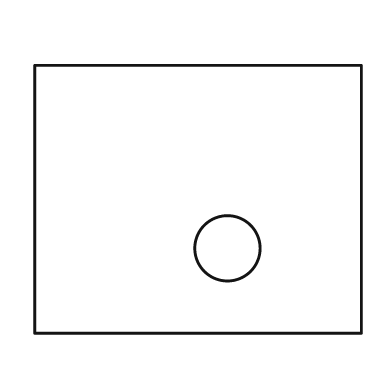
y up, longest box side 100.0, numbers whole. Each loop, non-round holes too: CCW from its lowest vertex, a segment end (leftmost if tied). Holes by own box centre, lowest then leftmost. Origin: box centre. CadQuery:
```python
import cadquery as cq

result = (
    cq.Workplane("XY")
    .moveTo(-50.0, -41.0)
    .lineTo(50.0, -41.0)
    .lineTo(50.0, 41.0)
    .lineTo(-50.0, 41.0)
    .close()
    .moveTo(9.0, -15.0)
    .circle(10.0)
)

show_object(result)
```